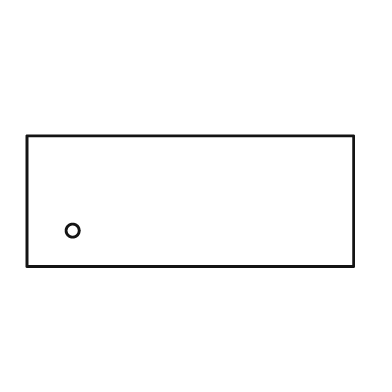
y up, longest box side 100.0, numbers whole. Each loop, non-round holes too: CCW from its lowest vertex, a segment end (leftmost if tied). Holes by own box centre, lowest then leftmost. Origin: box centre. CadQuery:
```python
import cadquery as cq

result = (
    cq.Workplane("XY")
    .moveTo(-50.0, -20.0)
    .lineTo(50.0, -20.0)
    .lineTo(50.0, 20.0)
    .lineTo(-50.0, 20.0)
    .close()
    .moveTo(-36.0, -9.0)
    .circle(2.0)
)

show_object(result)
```